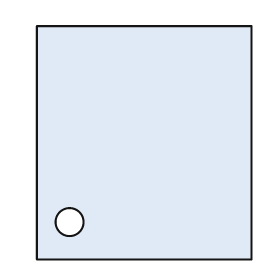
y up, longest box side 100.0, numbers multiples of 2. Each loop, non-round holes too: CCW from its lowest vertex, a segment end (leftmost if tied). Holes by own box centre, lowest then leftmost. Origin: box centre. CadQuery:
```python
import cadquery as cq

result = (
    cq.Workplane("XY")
    .moveTo(-46.0, -50.0)
    .lineTo(46.0, -50.0)
    .lineTo(46.0, 50.0)
    .lineTo(-46.0, 50.0)
    .close()
    .moveTo(-32.0, -34.0)
    .circle(6.0)
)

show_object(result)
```